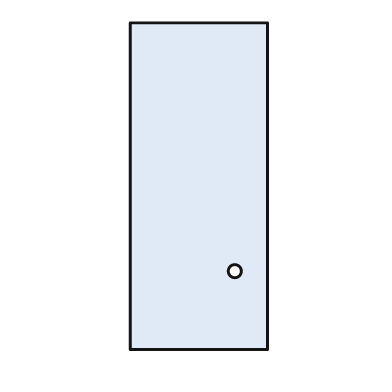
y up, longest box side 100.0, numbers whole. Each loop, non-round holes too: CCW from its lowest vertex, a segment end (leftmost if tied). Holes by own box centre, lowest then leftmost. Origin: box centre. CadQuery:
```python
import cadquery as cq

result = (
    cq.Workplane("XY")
    .moveTo(-21.0, -50.0)
    .lineTo(21.0, -50.0)
    .lineTo(21.0, 50.0)
    .lineTo(-21.0, 50.0)
    .close()
    .moveTo(11.0, -26.0)
    .circle(2.0)
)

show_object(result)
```